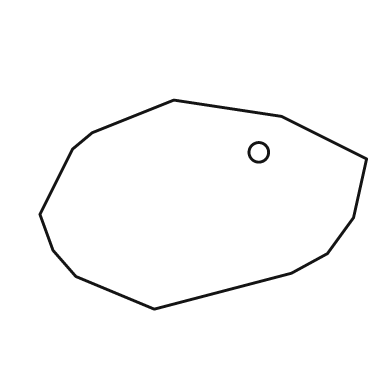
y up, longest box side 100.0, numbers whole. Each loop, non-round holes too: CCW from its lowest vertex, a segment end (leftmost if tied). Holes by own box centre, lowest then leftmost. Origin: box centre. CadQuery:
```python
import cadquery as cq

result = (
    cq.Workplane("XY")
    .moveTo(-15.0, -32.0)
    .lineTo(27.0, -21.0)
    .lineTo(38.0, -15.0)
    .lineTo(46.0, -4.0)
    .lineTo(50.0, 14.0)
    .lineTo(24.0, 27.0)
    .lineTo(-9.0, 32.0)
    .lineTo(-34.0, 22.0)
    .lineTo(-40.0, 17.0)
    .lineTo(-50.0, -3.0)
    .lineTo(-46.0, -14.0)
    .lineTo(-39.0, -22.0)
    .close()
    .moveTo(17.0, 16.0)
    .circle(3.0)
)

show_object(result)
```